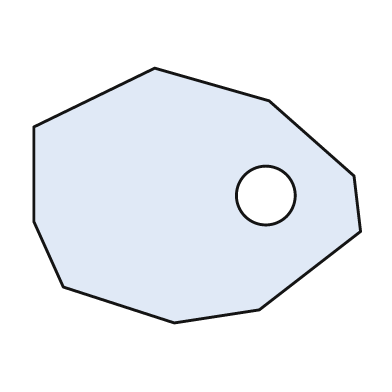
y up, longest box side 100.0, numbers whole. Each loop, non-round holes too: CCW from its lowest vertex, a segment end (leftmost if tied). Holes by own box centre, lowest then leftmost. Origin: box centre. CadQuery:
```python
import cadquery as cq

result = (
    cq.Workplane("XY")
    .moveTo(-7.0, -39.0)
    .lineTo(19.0, -35.0)
    .lineTo(50.0, -11.0)
    .lineTo(48.0, 6.0)
    .lineTo(22.0, 29.0)
    .lineTo(-13.0, 39.0)
    .lineTo(-50.0, 21.0)
    .lineTo(-50.0, -8.0)
    .lineTo(-41.0, -28.0)
    .close()
    .moveTo(21.0, 0.0)
    .circle(9.0)
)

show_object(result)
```